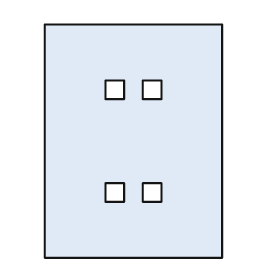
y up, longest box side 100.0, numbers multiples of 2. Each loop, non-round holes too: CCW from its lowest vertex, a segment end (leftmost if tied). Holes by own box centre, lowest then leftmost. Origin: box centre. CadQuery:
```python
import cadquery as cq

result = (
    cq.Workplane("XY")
    .moveTo(-38.0, -50.0)
    .lineTo(38.0, -50.0)
    .lineTo(38.0, 50.0)
    .lineTo(-38.0, 50.0)
    .close()
    .moveTo(-12.0, -26.0)
    .lineTo(-4.0, -26.0)
    .lineTo(-4.0, -18.0)
    .lineTo(-12.0, -18.0)
    .close()
    .moveTo(4.0, -26.0)
    .lineTo(12.0, -26.0)
    .lineTo(12.0, -18.0)
    .lineTo(4.0, -18.0)
    .close()
    .moveTo(-12.0, 18.0)
    .lineTo(-4.0, 18.0)
    .lineTo(-4.0, 26.0)
    .lineTo(-12.0, 26.0)
    .close()
    .moveTo(4.0, 18.0)
    .lineTo(12.0, 18.0)
    .lineTo(12.0, 26.0)
    .lineTo(4.0, 26.0)
    .close()
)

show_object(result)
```